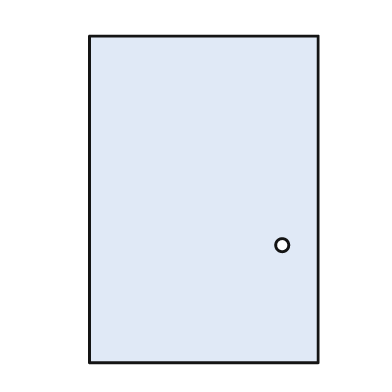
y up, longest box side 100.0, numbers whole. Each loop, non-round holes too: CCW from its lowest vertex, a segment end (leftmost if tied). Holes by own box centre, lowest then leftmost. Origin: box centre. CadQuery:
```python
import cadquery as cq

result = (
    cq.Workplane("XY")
    .moveTo(-35.0, -50.0)
    .lineTo(35.0, -50.0)
    .lineTo(35.0, 50.0)
    .lineTo(-35.0, 50.0)
    .close()
    .moveTo(24.0, -14.0)
    .circle(2.0)
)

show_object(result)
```